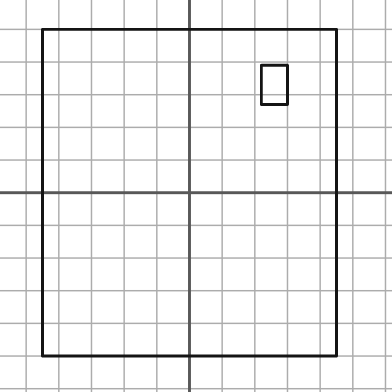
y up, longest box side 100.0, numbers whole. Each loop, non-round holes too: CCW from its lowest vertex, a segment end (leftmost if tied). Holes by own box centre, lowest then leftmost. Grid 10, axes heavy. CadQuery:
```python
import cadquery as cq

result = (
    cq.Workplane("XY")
    .moveTo(-45.0, -50.0)
    .lineTo(45.0, -50.0)
    .lineTo(45.0, 50.0)
    .lineTo(-45.0, 50.0)
    .close()
    .moveTo(22.0, 27.0)
    .lineTo(30.0, 27.0)
    .lineTo(30.0, 39.0)
    .lineTo(22.0, 39.0)
    .close()
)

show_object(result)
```